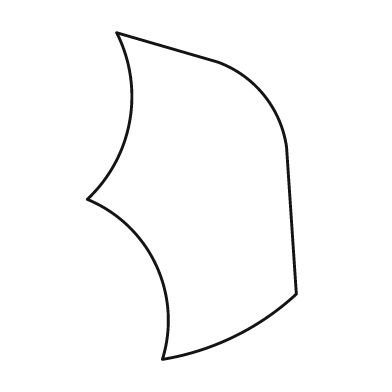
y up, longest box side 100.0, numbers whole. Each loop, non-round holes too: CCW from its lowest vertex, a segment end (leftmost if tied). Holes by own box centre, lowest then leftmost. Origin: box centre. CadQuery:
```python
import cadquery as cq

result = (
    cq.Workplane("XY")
    .moveTo(-9.0, -50.0)
    .threePointArc((13.0, -43.0), (32.0, -30.0))
    .lineTo(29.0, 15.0)
    .threePointArc((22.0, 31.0), (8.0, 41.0))
    .lineTo(-23.0, 50.0)
    .threePointArc((-19.0, 23.0), (-32.0, -1.0))
    .threePointArc((-11.0, -21.0), (-9.0, -50.0))
    .close()
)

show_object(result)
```